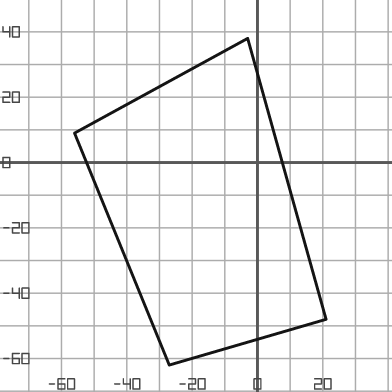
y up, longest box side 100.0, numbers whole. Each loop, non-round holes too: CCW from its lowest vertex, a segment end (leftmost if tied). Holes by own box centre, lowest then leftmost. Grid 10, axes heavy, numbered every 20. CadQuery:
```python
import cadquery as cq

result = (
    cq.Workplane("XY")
    .moveTo(-27.0, -62.0)
    .lineTo(21.0, -48.0)
    .lineTo(-3.0, 38.0)
    .lineTo(-56.0, 9.0)
    .close()
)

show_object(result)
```